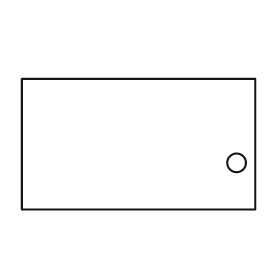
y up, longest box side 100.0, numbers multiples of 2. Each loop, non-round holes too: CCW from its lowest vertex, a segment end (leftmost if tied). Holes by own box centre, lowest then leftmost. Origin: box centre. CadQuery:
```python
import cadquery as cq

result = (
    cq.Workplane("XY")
    .moveTo(-50.0, -28.0)
    .lineTo(50.0, -28.0)
    .lineTo(50.0, 28.0)
    .lineTo(-50.0, 28.0)
    .close()
    .moveTo(42.0, -8.0)
    .circle(4.0)
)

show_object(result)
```